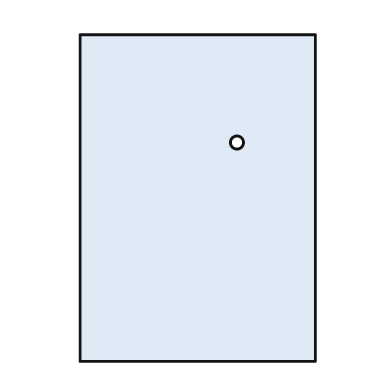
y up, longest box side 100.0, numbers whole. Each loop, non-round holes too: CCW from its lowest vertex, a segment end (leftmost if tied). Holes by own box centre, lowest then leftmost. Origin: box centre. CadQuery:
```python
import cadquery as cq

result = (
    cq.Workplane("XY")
    .moveTo(-36.0, -50.0)
    .lineTo(36.0, -50.0)
    .lineTo(36.0, 50.0)
    .lineTo(-36.0, 50.0)
    .close()
    .moveTo(12.0, 17.0)
    .circle(2.0)
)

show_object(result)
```